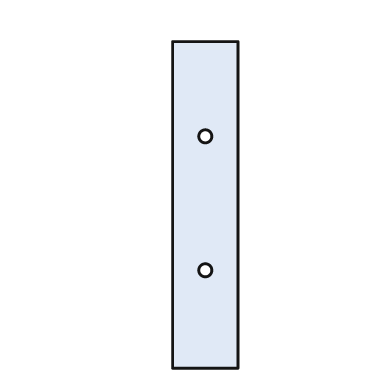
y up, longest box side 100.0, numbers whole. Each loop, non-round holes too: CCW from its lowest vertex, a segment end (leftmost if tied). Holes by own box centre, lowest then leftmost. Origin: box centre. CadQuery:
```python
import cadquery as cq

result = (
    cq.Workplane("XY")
    .moveTo(-10.0, -50.0)
    .lineTo(10.0, -50.0)
    .lineTo(10.0, 50.0)
    .lineTo(-10.0, 50.0)
    .close()
    .moveTo(0.0, -20.0)
    .circle(2.0)
    .moveTo(0.0, 21.0)
    .circle(2.0)
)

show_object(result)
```